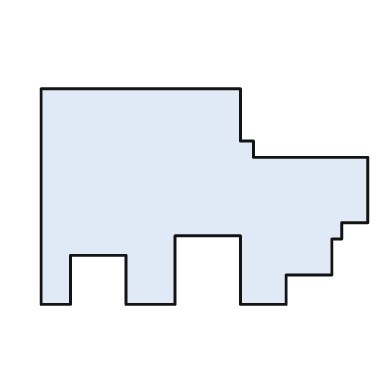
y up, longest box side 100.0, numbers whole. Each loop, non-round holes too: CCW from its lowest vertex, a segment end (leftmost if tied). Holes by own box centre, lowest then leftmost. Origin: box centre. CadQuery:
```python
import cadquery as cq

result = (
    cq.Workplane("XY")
    .moveTo(-50.0, -33.0)
    .lineTo(-41.0, -33.0)
    .lineTo(-41.0, -18.0)
    .lineTo(-24.0, -18.0)
    .lineTo(-24.0, -33.0)
    .lineTo(-9.0, -33.0)
    .lineTo(-9.0, -12.0)
    .lineTo(11.0, -12.0)
    .lineTo(11.0, -33.0)
    .lineTo(25.0, -33.0)
    .lineTo(25.0, -24.0)
    .lineTo(39.0, -24.0)
    .lineTo(39.0, -13.0)
    .lineTo(42.0, -13.0)
    .lineTo(42.0, -8.0)
    .lineTo(50.0, -8.0)
    .lineTo(50.0, 12.0)
    .lineTo(15.0, 12.0)
    .lineTo(15.0, 17.0)
    .lineTo(11.0, 17.0)
    .lineTo(11.0, 33.0)
    .lineTo(-50.0, 33.0)
    .close()
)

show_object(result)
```